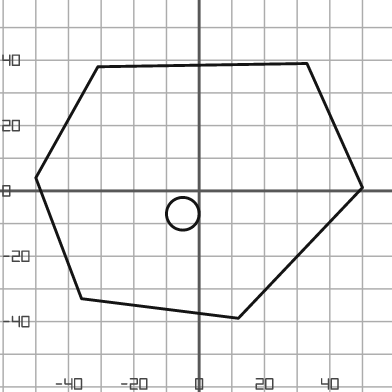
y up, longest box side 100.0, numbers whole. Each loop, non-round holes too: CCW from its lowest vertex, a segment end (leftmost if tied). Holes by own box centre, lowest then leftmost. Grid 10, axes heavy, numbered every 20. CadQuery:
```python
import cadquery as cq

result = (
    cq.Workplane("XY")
    .moveTo(12.0, -39.0)
    .lineTo(50.0, 1.0)
    .lineTo(33.0, 39.0)
    .lineTo(-31.0, 38.0)
    .lineTo(-50.0, 4.0)
    .lineTo(-36.0, -33.0)
    .close()
    .moveTo(-5.0, -7.0)
    .circle(5.0)
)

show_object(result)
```